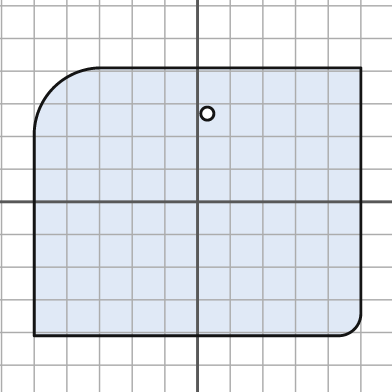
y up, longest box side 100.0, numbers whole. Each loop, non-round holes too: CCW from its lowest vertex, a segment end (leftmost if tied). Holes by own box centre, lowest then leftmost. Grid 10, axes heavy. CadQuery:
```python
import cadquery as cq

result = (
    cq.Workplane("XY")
    .moveTo(-50.0, -41.0)
    .lineTo(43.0, -41.0)
    .threePointArc((48.0, -39.0), (50.0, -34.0))
    .lineTo(50.0, 41.0)
    .lineTo(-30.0, 41.0)
    .threePointArc((-44.0, 35.0), (-50.0, 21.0))
    .close()
    .moveTo(3.0, 27.0)
    .circle(2.0)
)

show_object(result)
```